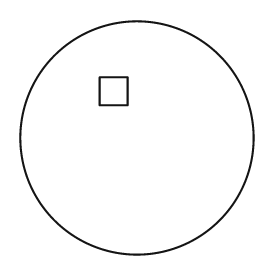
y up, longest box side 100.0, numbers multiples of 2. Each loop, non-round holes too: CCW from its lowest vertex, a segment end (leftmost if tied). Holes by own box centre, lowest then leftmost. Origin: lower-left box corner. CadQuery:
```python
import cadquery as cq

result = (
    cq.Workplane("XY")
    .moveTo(50.0, 50.0)
    .circle(50.0)
    .moveTo(34.0, 64.0)
    .lineTo(46.0, 64.0)
    .lineTo(46.0, 76.0)
    .lineTo(34.0, 76.0)
    .close()
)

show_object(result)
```